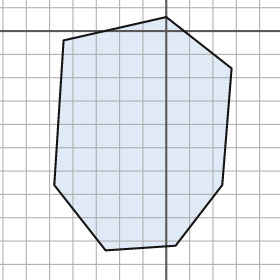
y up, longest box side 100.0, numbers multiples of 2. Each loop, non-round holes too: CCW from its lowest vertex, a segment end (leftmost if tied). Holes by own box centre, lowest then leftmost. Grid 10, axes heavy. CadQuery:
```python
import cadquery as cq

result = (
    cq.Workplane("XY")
    .moveTo(-26.0, -94.0)
    .lineTo(4.0, -92.0)
    .lineTo(24.0, -66.0)
    .lineTo(28.0, -16.0)
    .lineTo(0.0, 6.0)
    .lineTo(-44.0, -4.0)
    .lineTo(-48.0, -66.0)
    .close()
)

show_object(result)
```